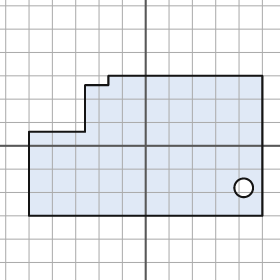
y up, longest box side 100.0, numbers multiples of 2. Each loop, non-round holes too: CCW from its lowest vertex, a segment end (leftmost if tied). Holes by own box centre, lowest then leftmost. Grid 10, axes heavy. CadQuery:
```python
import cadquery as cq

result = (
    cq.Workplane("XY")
    .moveTo(-50.0, -30.0)
    .lineTo(50.0, -30.0)
    .lineTo(50.0, 30.0)
    .lineTo(-16.0, 30.0)
    .lineTo(-16.0, 26.0)
    .lineTo(-26.0, 26.0)
    .lineTo(-26.0, 6.0)
    .lineTo(-50.0, 6.0)
    .close()
    .moveTo(42.0, -18.0)
    .circle(4.0)
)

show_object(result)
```